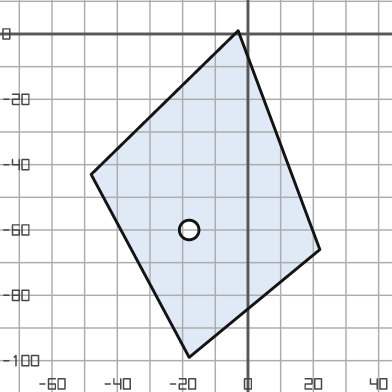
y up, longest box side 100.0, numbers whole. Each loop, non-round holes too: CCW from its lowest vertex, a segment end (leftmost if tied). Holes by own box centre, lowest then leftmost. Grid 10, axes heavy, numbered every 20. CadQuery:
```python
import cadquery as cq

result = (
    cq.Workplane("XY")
    .moveTo(-18.0, -99.0)
    .lineTo(22.0, -66.0)
    .lineTo(-3.0, 1.0)
    .lineTo(-48.0, -43.0)
    .close()
    .moveTo(-18.0, -60.0)
    .circle(3.0)
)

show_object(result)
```